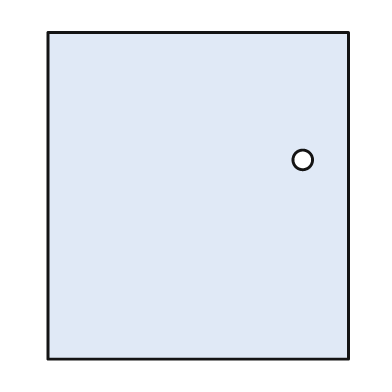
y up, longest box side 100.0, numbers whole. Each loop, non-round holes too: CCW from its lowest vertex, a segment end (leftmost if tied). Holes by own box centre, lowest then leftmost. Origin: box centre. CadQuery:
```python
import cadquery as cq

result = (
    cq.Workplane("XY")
    .moveTo(-46.0, -50.0)
    .lineTo(46.0, -50.0)
    .lineTo(46.0, 50.0)
    .lineTo(-46.0, 50.0)
    .close()
    .moveTo(32.0, 11.0)
    .circle(3.0)
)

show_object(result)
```